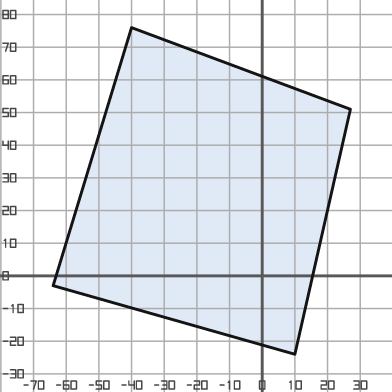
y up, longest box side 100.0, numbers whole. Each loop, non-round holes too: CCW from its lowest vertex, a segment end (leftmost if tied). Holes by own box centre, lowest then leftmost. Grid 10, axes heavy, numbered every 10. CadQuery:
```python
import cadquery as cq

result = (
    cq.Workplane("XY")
    .moveTo(10.0, -24.0)
    .lineTo(27.0, 51.0)
    .lineTo(-40.0, 76.0)
    .lineTo(-64.0, -3.0)
    .close()
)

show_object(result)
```